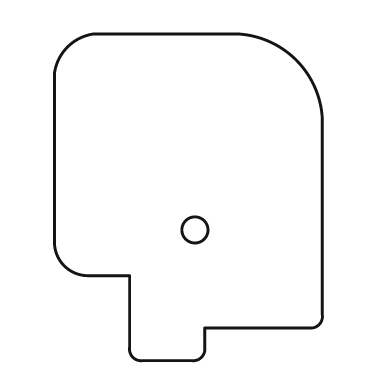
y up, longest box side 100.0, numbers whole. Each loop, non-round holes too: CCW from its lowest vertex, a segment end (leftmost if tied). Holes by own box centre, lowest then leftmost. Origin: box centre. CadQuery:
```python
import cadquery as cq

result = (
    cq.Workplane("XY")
    .moveTo(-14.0, -50.0)
    .lineTo(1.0, -50.0)
    .threePointArc((4.0, -49.0), (5.0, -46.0))
    .lineTo(5.0, -40.0)
    .lineTo(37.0, -40.0)
    .threePointArc((40.0, -39.0), (41.0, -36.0))
    .lineTo(41.0, 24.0)
    .threePointArc((33.0, 42.0), (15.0, 50.0))
    .lineTo(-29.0, 50.0)
    .threePointArc((-37.0, 46.0), (-41.0, 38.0))
    .lineTo(-41.0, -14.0)
    .threePointArc((-38.0, -21.0), (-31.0, -24.0))
    .lineTo(-18.0, -24.0)
    .lineTo(-18.0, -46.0)
    .threePointArc((-17.0, -49.0), (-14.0, -50.0))
    .close()
    .moveTo(2.0, -10.0)
    .circle(4.0)
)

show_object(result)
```